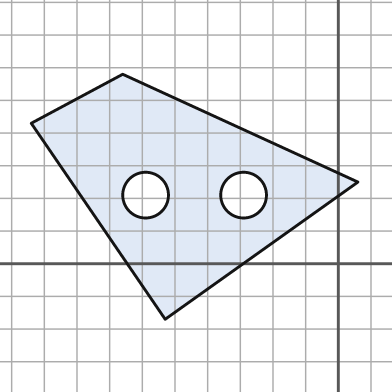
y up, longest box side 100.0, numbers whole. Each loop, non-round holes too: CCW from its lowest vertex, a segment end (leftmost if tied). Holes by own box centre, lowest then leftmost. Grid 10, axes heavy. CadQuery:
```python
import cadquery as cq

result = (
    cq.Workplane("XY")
    .moveTo(-53.0, -17.0)
    .lineTo(6.0, 25.0)
    .lineTo(-66.0, 58.0)
    .lineTo(-94.0, 43.0)
    .close()
    .moveTo(-59.0, 21.0)
    .circle(7.0)
    .moveTo(-29.0, 21.0)
    .circle(7.0)
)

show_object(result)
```